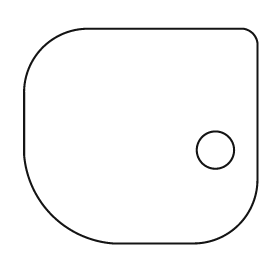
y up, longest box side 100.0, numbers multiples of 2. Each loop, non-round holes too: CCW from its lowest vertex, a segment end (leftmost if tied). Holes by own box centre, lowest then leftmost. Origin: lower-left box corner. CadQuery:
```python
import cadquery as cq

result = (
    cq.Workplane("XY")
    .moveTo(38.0, 0.0)
    .lineTo(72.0, 0.0)
    .threePointArc((92.0, 8.0), (100.0, 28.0))
    .lineTo(100.0, 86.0)
    .threePointArc((98.0, 90.0), (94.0, 92.0))
    .lineTo(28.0, 92.0)
    .threePointArc((8.0, 84.0), (0.0, 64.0))
    .lineTo(0.0, 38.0)
    .threePointArc((12.0, 12.0), (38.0, 0.0))
    .close()
    .moveTo(82.0, 40.0)
    .circle(8.0)
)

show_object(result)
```